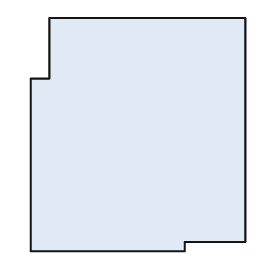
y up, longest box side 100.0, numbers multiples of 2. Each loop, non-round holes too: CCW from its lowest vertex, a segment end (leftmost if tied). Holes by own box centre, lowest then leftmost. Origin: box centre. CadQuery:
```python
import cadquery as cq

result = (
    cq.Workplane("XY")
    .moveTo(-46.0, -50.0)
    .lineTo(20.0, -50.0)
    .lineTo(20.0, -46.0)
    .lineTo(46.0, -46.0)
    .lineTo(46.0, 50.0)
    .lineTo(-38.0, 50.0)
    .lineTo(-38.0, 24.0)
    .lineTo(-46.0, 24.0)
    .close()
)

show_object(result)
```